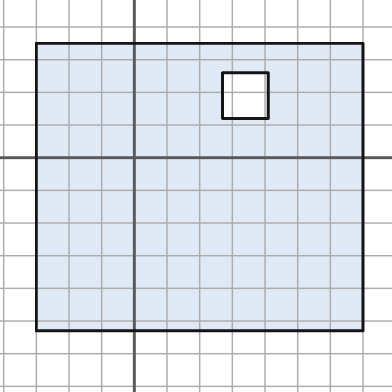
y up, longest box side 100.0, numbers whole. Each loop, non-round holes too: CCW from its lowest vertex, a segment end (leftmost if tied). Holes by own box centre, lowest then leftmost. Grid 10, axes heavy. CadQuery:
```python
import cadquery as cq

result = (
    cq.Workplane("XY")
    .moveTo(-30.0, -53.0)
    .lineTo(70.0, -53.0)
    .lineTo(70.0, 35.0)
    .lineTo(-30.0, 35.0)
    .close()
    .moveTo(27.0, 12.0)
    .lineTo(41.0, 12.0)
    .lineTo(41.0, 26.0)
    .lineTo(27.0, 26.0)
    .close()
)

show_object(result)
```